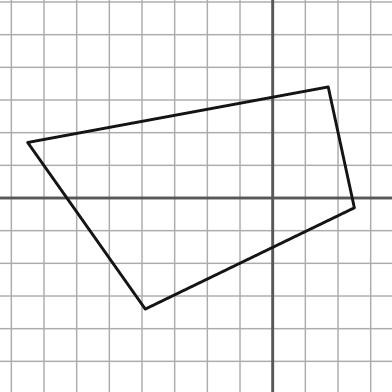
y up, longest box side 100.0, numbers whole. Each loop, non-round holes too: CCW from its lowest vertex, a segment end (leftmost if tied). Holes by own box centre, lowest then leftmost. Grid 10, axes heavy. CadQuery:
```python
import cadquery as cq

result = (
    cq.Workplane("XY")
    .moveTo(-39.0, -34.0)
    .lineTo(25.0, -3.0)
    .lineTo(17.0, 34.0)
    .lineTo(-75.0, 17.0)
    .close()
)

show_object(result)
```